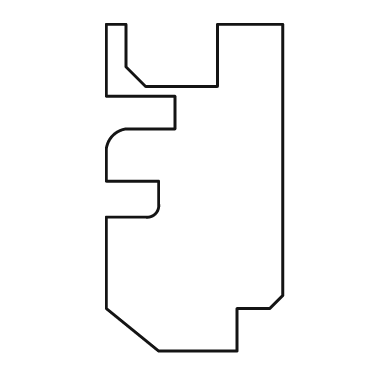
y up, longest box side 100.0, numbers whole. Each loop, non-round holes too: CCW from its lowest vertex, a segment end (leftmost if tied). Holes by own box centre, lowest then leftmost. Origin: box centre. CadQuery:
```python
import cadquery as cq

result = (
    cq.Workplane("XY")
    .moveTo(-11.0, -50.0)
    .lineTo(13.0, -50.0)
    .lineTo(13.0, -37.0)
    .lineTo(23.0, -37.0)
    .lineTo(27.0, -33.0)
    .lineTo(27.0, 50.0)
    .lineTo(7.0, 50.0)
    .lineTo(7.0, 31.0)
    .lineTo(-15.0, 31.0)
    .lineTo(-21.0, 37.0)
    .lineTo(-21.0, 50.0)
    .lineTo(-27.0, 50.0)
    .lineTo(-27.0, 28.0)
    .lineTo(-6.0, 28.0)
    .lineTo(-6.0, 18.0)
    .lineTo(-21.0, 18.0)
    .threePointArc((-25.0, 16.0), (-27.0, 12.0))
    .lineTo(-27.0, 2.0)
    .lineTo(-11.0, 2.0)
    .lineTo(-11.0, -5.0)
    .threePointArc((-12.0, -8.0), (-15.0, -9.0))
    .lineTo(-27.0, -9.0)
    .lineTo(-27.0, -37.0)
    .close()
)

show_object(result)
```